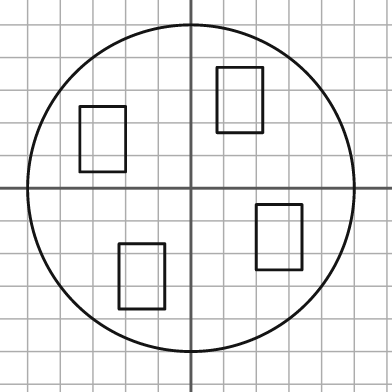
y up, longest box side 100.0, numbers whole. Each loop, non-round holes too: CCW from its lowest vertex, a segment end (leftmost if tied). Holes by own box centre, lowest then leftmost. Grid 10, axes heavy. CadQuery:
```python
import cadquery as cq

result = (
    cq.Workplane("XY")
    .moveTo(0.0, 0.0)
    .circle(50.0)
    .moveTo(-22.0, -37.0)
    .lineTo(-8.0, -37.0)
    .lineTo(-8.0, -17.0)
    .lineTo(-22.0, -17.0)
    .close()
    .moveTo(20.0, -25.0)
    .lineTo(34.0, -25.0)
    .lineTo(34.0, -5.0)
    .lineTo(20.0, -5.0)
    .close()
    .moveTo(-34.0, 5.0)
    .lineTo(-20.0, 5.0)
    .lineTo(-20.0, 25.0)
    .lineTo(-34.0, 25.0)
    .close()
    .moveTo(8.0, 17.0)
    .lineTo(22.0, 17.0)
    .lineTo(22.0, 37.0)
    .lineTo(8.0, 37.0)
    .close()
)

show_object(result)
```